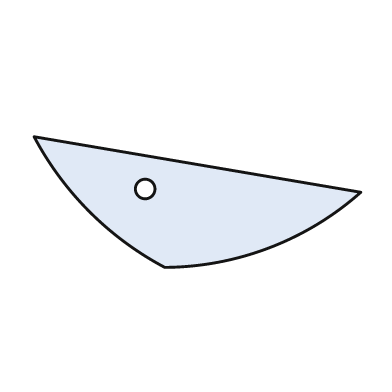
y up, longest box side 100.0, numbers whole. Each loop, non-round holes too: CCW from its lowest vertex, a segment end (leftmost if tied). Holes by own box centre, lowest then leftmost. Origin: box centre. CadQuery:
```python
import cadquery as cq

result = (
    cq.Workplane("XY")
    .moveTo(-10.0, -20.0)
    .threePointArc((22.0, -14.0), (50.0, 3.0))
    .lineTo(-50.0, 20.0)
    .threePointArc((-33.0, -3.0), (-10.0, -20.0))
    .close()
    .moveTo(-16.0, 4.0)
    .circle(3.0)
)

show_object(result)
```